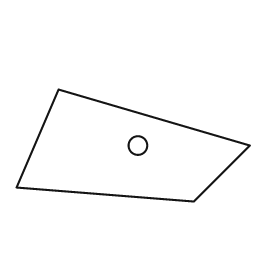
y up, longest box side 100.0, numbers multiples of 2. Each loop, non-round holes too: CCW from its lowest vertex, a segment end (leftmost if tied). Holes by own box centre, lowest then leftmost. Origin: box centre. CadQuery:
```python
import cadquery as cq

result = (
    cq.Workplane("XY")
    .moveTo(26.0, -24.0)
    .lineTo(50.0, 0.0)
    .lineTo(-32.0, 24.0)
    .lineTo(-50.0, -18.0)
    .close()
    .moveTo(2.0, 0.0)
    .circle(4.0)
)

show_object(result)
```